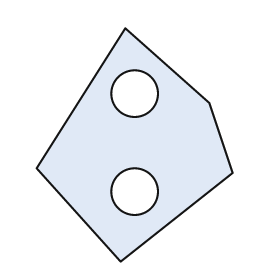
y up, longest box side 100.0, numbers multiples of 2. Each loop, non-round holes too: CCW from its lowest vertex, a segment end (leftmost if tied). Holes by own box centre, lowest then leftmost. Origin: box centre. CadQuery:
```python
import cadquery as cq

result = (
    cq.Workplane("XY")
    .moveTo(-6.0, -50.0)
    .lineTo(42.0, -12.0)
    .lineTo(32.0, 18.0)
    .lineTo(-4.0, 50.0)
    .lineTo(-42.0, -10.0)
    .close()
    .moveTo(0.0, -20.0)
    .circle(10.0)
    .moveTo(0.0, 22.0)
    .circle(10.0)
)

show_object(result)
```